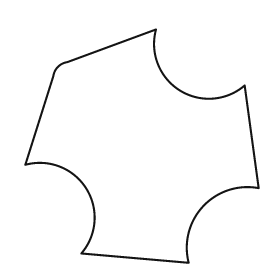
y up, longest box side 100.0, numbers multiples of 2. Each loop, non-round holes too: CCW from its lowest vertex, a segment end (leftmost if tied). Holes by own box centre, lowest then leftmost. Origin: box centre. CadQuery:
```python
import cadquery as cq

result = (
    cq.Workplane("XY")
    .moveTo(20.0, -50.0)
    .threePointArc((26.0, -26.0), (50.0, -18.0))
    .lineTo(44.0, 26.0)
    .threePointArc((16.0, 24.0), (6.0, 50.0))
    .lineTo(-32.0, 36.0)
    .threePointArc((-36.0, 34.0), (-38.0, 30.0))
    .lineTo(-50.0, -8.0)
    .threePointArc((-24.0, -18.0), (-26.0, -46.0))
    .close()
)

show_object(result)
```